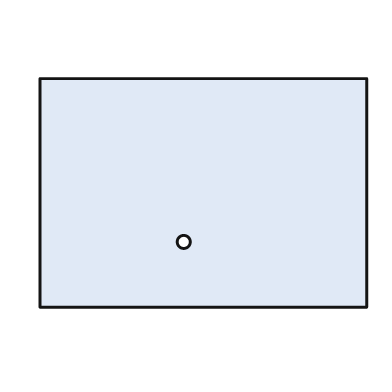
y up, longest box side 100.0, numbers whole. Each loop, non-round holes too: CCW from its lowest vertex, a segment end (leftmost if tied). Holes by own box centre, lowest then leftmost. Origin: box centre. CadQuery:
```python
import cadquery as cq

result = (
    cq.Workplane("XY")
    .moveTo(-50.0, -35.0)
    .lineTo(50.0, -35.0)
    .lineTo(50.0, 35.0)
    .lineTo(-50.0, 35.0)
    .close()
    .moveTo(-6.0, -15.0)
    .circle(2.0)
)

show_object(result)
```